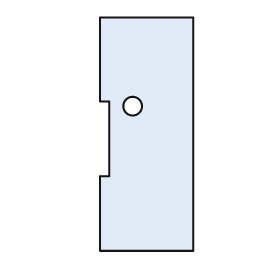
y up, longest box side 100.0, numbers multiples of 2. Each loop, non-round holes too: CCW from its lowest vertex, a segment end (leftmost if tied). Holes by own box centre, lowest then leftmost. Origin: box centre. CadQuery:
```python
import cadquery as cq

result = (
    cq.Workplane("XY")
    .moveTo(-20.0, -50.0)
    .lineTo(20.0, -50.0)
    .lineTo(20.0, 50.0)
    .lineTo(-20.0, 50.0)
    .lineTo(-20.0, 14.0)
    .lineTo(-16.0, 14.0)
    .lineTo(-16.0, -18.0)
    .lineTo(-20.0, -18.0)
    .close()
    .moveTo(-6.0, 12.0)
    .circle(4.0)
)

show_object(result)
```